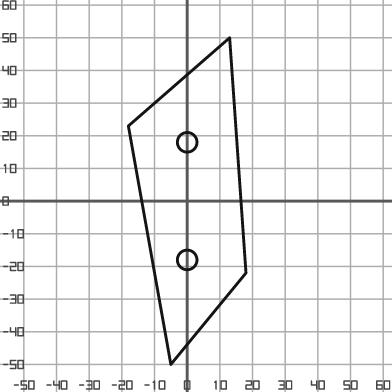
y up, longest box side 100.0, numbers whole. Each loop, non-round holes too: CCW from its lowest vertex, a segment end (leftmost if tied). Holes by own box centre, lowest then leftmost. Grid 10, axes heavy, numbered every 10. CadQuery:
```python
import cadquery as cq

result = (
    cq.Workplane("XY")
    .moveTo(-5.0, -50.0)
    .lineTo(18.0, -22.0)
    .lineTo(13.0, 50.0)
    .lineTo(-18.0, 23.0)
    .close()
    .moveTo(0.0, -18.0)
    .circle(3.0)
    .moveTo(0.0, 18.0)
    .circle(3.0)
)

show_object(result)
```